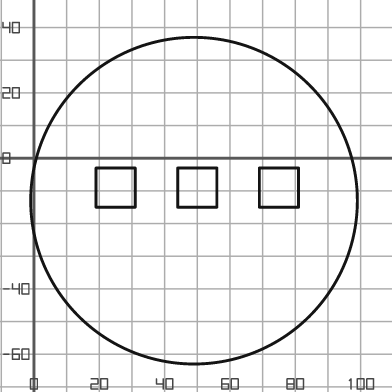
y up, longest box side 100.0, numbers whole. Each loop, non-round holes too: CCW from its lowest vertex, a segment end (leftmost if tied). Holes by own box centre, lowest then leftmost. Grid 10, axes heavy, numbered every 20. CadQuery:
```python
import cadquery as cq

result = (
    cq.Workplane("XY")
    .moveTo(49.0, -13.0)
    .circle(50.0)
    .moveTo(19.0, -15.0)
    .lineTo(31.0, -15.0)
    .lineTo(31.0, -3.0)
    .lineTo(19.0, -3.0)
    .close()
    .moveTo(44.0, -15.0)
    .lineTo(56.0, -15.0)
    .lineTo(56.0, -3.0)
    .lineTo(44.0, -3.0)
    .close()
    .moveTo(69.0, -15.0)
    .lineTo(81.0, -15.0)
    .lineTo(81.0, -3.0)
    .lineTo(69.0, -3.0)
    .close()
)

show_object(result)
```